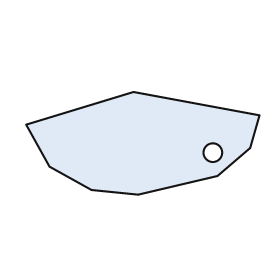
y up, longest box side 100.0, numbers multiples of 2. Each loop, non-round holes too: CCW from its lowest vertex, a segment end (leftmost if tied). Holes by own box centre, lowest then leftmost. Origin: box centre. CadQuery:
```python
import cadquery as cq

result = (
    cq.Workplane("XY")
    .moveTo(-2.0, -22.0)
    .lineTo(32.0, -14.0)
    .lineTo(46.0, -2.0)
    .lineTo(50.0, 12.0)
    .lineTo(-4.0, 22.0)
    .lineTo(-50.0, 8.0)
    .lineTo(-40.0, -10.0)
    .lineTo(-22.0, -20.0)
    .close()
    .moveTo(30.0, -4.0)
    .circle(4.0)
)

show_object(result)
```